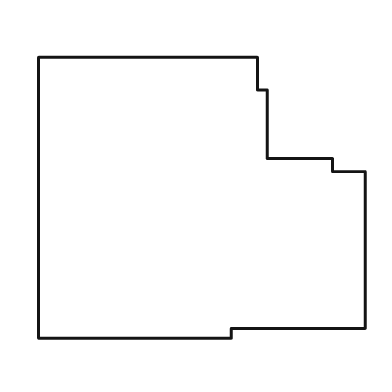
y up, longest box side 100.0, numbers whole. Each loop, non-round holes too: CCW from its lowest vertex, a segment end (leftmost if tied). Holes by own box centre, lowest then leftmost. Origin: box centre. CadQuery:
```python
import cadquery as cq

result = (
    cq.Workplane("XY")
    .moveTo(-50.0, -43.0)
    .lineTo(9.0, -43.0)
    .lineTo(9.0, -40.0)
    .lineTo(50.0, -40.0)
    .lineTo(50.0, 8.0)
    .lineTo(40.0, 8.0)
    .lineTo(40.0, 12.0)
    .lineTo(20.0, 12.0)
    .lineTo(20.0, 33.0)
    .lineTo(17.0, 33.0)
    .lineTo(17.0, 43.0)
    .lineTo(-50.0, 43.0)
    .close()
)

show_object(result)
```